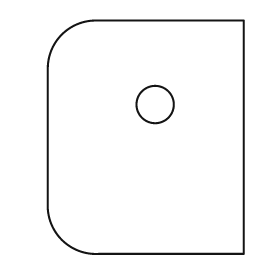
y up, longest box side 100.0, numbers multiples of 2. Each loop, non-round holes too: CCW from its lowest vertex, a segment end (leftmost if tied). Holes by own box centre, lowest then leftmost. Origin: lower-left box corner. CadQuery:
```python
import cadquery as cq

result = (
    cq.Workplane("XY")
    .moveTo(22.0, 0.0)
    .lineTo(84.0, 0.0)
    .lineTo(84.0, 100.0)
    .lineTo(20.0, 100.0)
    .threePointArc((6.0, 94.0), (0.0, 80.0))
    .lineTo(0.0, 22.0)
    .threePointArc((6.0, 6.0), (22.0, 0.0))
    .close()
    .moveTo(46.0, 64.0)
    .circle(8.0)
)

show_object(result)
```